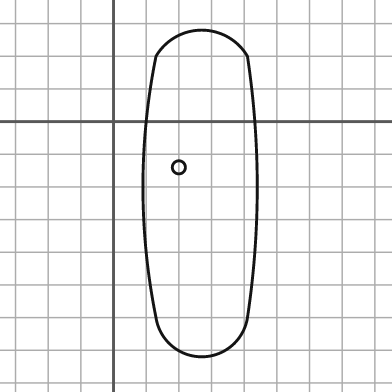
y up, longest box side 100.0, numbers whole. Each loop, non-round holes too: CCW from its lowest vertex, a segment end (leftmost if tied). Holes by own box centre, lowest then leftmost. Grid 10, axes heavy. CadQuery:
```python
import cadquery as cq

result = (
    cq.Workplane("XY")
    .moveTo(13.0, -60.0)
    .threePointArc((27.0, -72.0), (41.0, -60.0))
    .threePointArc((44.0, -20.0), (41.0, 20.0))
    .threePointArc((27.0, 28.0), (13.0, 20.0))
    .threePointArc((9.0, -20.0), (13.0, -60.0))
    .close()
    .moveTo(20.0, -14.0)
    .circle(2.0)
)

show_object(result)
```